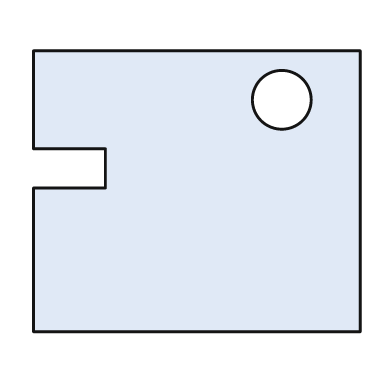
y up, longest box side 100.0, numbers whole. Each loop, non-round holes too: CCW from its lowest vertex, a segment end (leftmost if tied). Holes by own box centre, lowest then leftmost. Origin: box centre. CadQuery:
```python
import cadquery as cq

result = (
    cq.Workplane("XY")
    .moveTo(-50.0, -43.0)
    .lineTo(50.0, -43.0)
    .lineTo(50.0, 43.0)
    .lineTo(-50.0, 43.0)
    .lineTo(-50.0, 13.0)
    .lineTo(-28.0, 13.0)
    .lineTo(-28.0, 1.0)
    .lineTo(-50.0, 1.0)
    .close()
    .moveTo(26.0, 28.0)
    .circle(9.0)
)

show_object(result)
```